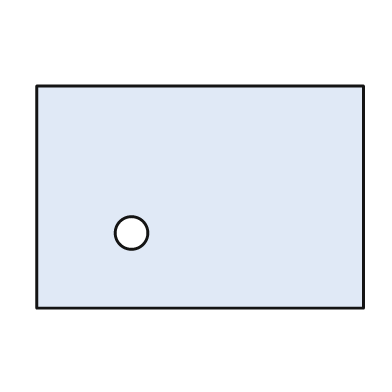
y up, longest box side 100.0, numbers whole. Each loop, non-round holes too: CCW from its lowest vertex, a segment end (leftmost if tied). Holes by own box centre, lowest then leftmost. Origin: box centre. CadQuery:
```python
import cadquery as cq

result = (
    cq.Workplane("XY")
    .moveTo(-50.0, -34.0)
    .lineTo(50.0, -34.0)
    .lineTo(50.0, 34.0)
    .lineTo(-50.0, 34.0)
    .close()
    .moveTo(-21.0, -11.0)
    .circle(5.0)
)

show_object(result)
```